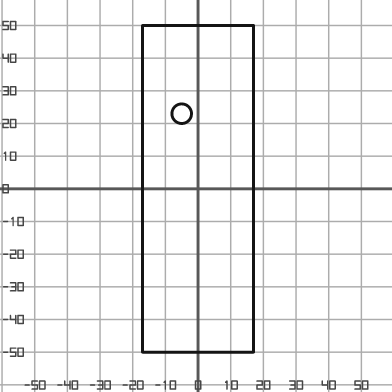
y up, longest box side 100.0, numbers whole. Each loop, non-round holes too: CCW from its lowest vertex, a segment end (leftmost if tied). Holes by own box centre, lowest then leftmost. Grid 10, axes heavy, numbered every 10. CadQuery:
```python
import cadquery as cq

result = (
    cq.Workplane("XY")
    .moveTo(-17.0, -50.0)
    .lineTo(17.0, -50.0)
    .lineTo(17.0, 50.0)
    .lineTo(-17.0, 50.0)
    .close()
    .moveTo(-5.0, 23.0)
    .circle(3.0)
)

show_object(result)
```